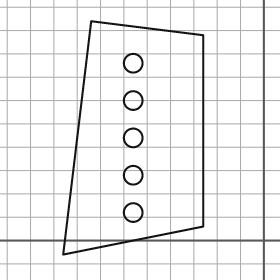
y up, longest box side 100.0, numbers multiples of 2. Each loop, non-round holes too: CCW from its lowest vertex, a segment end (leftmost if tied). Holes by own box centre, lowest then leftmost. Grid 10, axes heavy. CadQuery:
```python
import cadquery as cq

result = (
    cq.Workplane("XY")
    .moveTo(-86.0, -6.0)
    .lineTo(-26.0, 6.0)
    .lineTo(-26.0, 88.0)
    .lineTo(-74.0, 94.0)
    .close()
    .moveTo(-56.0, 12.0)
    .circle(4.0)
    .moveTo(-56.0, 28.0)
    .circle(4.0)
    .moveTo(-56.0, 44.0)
    .circle(4.0)
    .moveTo(-56.0, 60.0)
    .circle(4.0)
    .moveTo(-56.0, 76.0)
    .circle(4.0)
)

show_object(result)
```